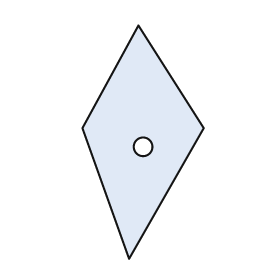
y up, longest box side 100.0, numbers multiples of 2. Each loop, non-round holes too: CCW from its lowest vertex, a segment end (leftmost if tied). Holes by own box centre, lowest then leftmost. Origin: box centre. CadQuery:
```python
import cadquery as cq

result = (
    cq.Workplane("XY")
    .moveTo(-6.0, -50.0)
    .lineTo(26.0, 6.0)
    .lineTo(-2.0, 50.0)
    .lineTo(-26.0, 6.0)
    .close()
    .moveTo(0.0, -2.0)
    .circle(4.0)
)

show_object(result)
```